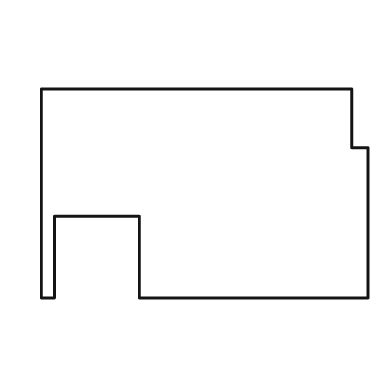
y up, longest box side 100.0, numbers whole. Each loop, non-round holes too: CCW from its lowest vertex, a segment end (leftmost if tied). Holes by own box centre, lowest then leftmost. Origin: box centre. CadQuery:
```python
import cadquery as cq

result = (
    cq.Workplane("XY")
    .moveTo(-50.0, -32.0)
    .lineTo(-46.0, -32.0)
    .lineTo(-46.0, -7.0)
    .lineTo(-20.0, -7.0)
    .lineTo(-20.0, -32.0)
    .lineTo(50.0, -32.0)
    .lineTo(50.0, 14.0)
    .lineTo(45.0, 14.0)
    .lineTo(45.0, 32.0)
    .lineTo(-50.0, 32.0)
    .close()
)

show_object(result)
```